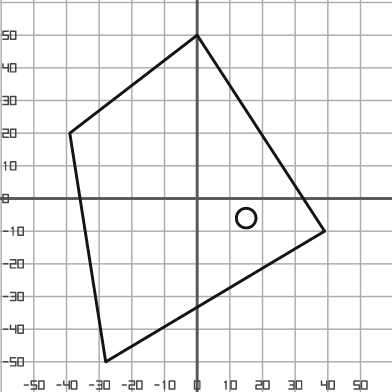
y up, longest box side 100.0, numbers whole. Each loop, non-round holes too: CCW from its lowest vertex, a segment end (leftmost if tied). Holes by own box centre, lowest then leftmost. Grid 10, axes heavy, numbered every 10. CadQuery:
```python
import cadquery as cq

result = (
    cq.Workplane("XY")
    .moveTo(-28.0, -50.0)
    .lineTo(39.0, -10.0)
    .lineTo(0.0, 50.0)
    .lineTo(-39.0, 20.0)
    .close()
    .moveTo(15.0, -6.0)
    .circle(3.0)
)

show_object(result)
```